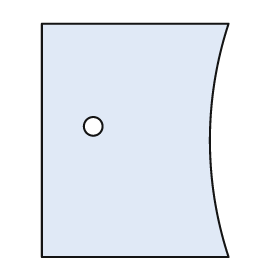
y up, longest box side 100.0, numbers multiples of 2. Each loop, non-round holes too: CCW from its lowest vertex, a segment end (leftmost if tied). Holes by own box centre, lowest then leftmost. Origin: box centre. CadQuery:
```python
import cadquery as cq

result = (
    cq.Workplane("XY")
    .moveTo(-40.0, -50.0)
    .lineTo(40.0, -50.0)
    .threePointArc((32.0, 0.0), (40.0, 50.0))
    .lineTo(-40.0, 50.0)
    .close()
    .moveTo(-18.0, 6.0)
    .circle(4.0)
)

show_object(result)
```